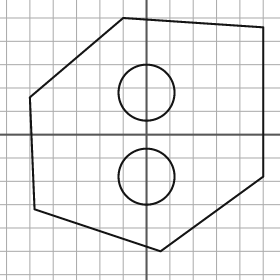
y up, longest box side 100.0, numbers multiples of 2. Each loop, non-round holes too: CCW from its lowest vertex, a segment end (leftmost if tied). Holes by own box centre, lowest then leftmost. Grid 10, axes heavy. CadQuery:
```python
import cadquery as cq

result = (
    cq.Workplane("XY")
    .moveTo(6.0, -50.0)
    .lineTo(50.0, -18.0)
    .lineTo(50.0, 46.0)
    .lineTo(-10.0, 50.0)
    .lineTo(-50.0, 16.0)
    .lineTo(-48.0, -32.0)
    .close()
    .moveTo(0.0, -18.0)
    .circle(12.0)
    .moveTo(0.0, 18.0)
    .circle(12.0)
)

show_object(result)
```